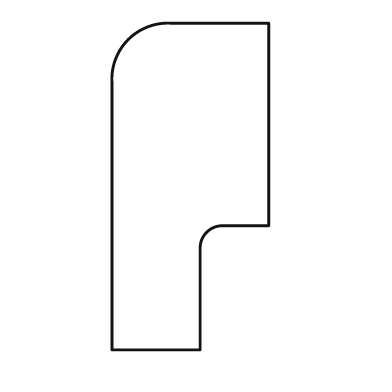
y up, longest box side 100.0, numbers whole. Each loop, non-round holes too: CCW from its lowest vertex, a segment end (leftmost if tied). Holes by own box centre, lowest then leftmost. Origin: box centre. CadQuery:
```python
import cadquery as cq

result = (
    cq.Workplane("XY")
    .moveTo(-24.0, -50.0)
    .lineTo(3.0, -50.0)
    .lineTo(3.0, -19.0)
    .threePointArc((5.0, -14.0), (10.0, -12.0))
    .lineTo(24.0, -12.0)
    .lineTo(24.0, 50.0)
    .lineTo(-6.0, 50.0)
    .threePointArc((-19.0, 45.0), (-24.0, 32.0))
    .close()
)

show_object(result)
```